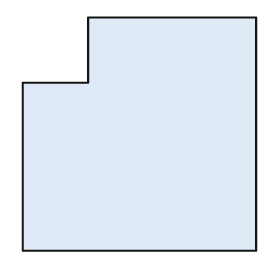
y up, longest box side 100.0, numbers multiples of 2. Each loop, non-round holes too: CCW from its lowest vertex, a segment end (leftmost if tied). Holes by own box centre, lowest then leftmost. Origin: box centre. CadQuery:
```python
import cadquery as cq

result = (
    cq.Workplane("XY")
    .moveTo(-50.0, -50.0)
    .lineTo(50.0, -50.0)
    .lineTo(50.0, 50.0)
    .lineTo(-22.0, 50.0)
    .lineTo(-22.0, 22.0)
    .lineTo(-50.0, 22.0)
    .close()
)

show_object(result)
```